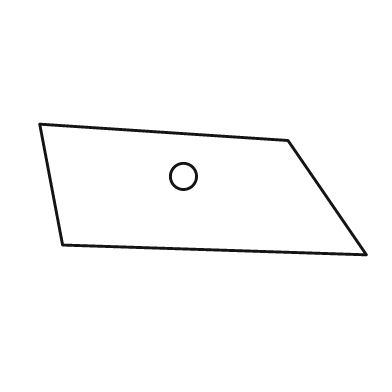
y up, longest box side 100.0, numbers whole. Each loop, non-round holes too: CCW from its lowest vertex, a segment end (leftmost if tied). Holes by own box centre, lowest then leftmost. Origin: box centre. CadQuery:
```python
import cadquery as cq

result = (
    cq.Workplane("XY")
    .moveTo(50.0, -20.0)
    .lineTo(26.0, 15.0)
    .lineTo(-50.0, 20.0)
    .lineTo(-43.0, -17.0)
    .close()
    .moveTo(-6.0, 4.0)
    .circle(4.0)
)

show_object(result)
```